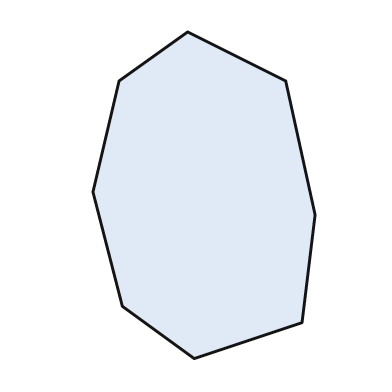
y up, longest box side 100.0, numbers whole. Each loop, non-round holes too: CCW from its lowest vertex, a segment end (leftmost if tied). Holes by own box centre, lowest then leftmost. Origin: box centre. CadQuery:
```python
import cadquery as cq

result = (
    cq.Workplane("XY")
    .moveTo(-3.0, -50.0)
    .lineTo(30.0, -39.0)
    .lineTo(34.0, -6.0)
    .lineTo(25.0, 35.0)
    .lineTo(-5.0, 50.0)
    .lineTo(-26.0, 35.0)
    .lineTo(-34.0, 1.0)
    .lineTo(-25.0, -34.0)
    .close()
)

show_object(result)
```